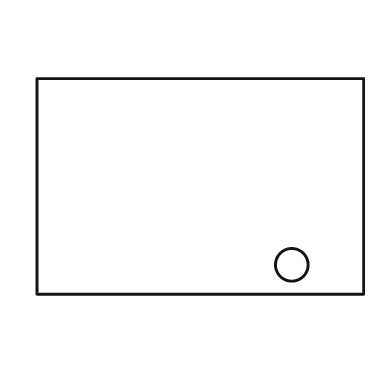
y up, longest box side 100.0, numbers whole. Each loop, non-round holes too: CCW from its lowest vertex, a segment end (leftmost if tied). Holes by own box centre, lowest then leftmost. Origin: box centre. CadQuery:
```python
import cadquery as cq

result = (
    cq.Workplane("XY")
    .moveTo(-50.0, -33.0)
    .lineTo(50.0, -33.0)
    .lineTo(50.0, 33.0)
    .lineTo(-50.0, 33.0)
    .close()
    .moveTo(28.0, -24.0)
    .circle(5.0)
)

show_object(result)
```